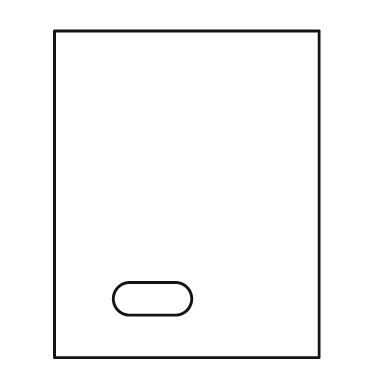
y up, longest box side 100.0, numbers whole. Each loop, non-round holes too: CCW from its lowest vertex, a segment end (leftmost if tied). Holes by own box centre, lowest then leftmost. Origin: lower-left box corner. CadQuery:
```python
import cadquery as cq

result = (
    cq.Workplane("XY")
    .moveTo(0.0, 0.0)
    .lineTo(81.0, 0.0)
    .lineTo(81.0, 100.0)
    .lineTo(0.0, 100.0)
    .close()
    .moveTo(23.0, 13.0)
    .lineTo(37.0, 13.0)
    .threePointArc((42.0, 18.0), (37.0, 23.0))
    .lineTo(23.0, 23.0)
    .threePointArc((18.0, 18.0), (23.0, 13.0))
    .close()
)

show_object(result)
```